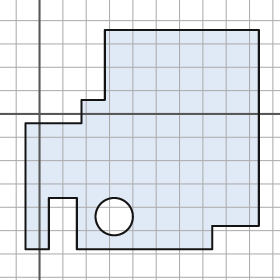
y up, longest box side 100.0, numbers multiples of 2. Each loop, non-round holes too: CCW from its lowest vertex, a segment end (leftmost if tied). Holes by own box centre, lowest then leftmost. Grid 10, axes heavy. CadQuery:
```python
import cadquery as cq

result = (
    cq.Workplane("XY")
    .moveTo(-6.0, -58.0)
    .lineTo(4.0, -58.0)
    .lineTo(4.0, -36.0)
    .lineTo(16.0, -36.0)
    .lineTo(16.0, -58.0)
    .lineTo(74.0, -58.0)
    .lineTo(74.0, -48.0)
    .lineTo(94.0, -48.0)
    .lineTo(94.0, 36.0)
    .lineTo(28.0, 36.0)
    .lineTo(28.0, 6.0)
    .lineTo(18.0, 6.0)
    .lineTo(18.0, -4.0)
    .lineTo(-6.0, -4.0)
    .close()
    .moveTo(32.0, -44.0)
    .circle(8.0)
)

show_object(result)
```